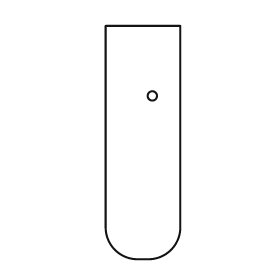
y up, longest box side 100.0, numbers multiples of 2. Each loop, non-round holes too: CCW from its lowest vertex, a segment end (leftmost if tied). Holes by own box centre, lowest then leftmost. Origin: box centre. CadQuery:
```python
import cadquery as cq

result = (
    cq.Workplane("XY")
    .moveTo(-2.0, -50.0)
    .lineTo(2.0, -50.0)
    .threePointArc((12.0, -46.0), (16.0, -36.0))
    .lineTo(16.0, 50.0)
    .lineTo(-16.0, 50.0)
    .lineTo(-16.0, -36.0)
    .threePointArc((-12.0, -46.0), (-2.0, -50.0))
    .close()
    .moveTo(4.0, 20.0)
    .circle(2.0)
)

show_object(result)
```